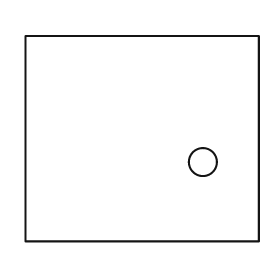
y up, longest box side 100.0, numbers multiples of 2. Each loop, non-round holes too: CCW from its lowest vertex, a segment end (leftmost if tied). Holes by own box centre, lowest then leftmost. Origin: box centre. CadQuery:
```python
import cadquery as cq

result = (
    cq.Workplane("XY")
    .moveTo(-50.0, -44.0)
    .lineTo(50.0, -44.0)
    .lineTo(50.0, 44.0)
    .lineTo(-50.0, 44.0)
    .close()
    .moveTo(26.0, -10.0)
    .circle(6.0)
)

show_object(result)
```